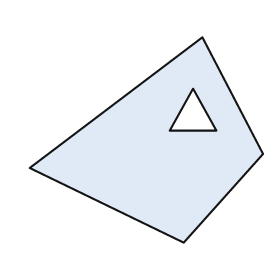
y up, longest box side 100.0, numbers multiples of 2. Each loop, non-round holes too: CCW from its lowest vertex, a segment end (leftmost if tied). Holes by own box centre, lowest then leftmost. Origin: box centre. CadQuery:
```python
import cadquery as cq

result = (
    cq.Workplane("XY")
    .moveTo(16.0, -44.0)
    .lineTo(50.0, -6.0)
    .lineTo(24.0, 44.0)
    .lineTo(-50.0, -12.0)
    .close()
    .moveTo(10.0, 4.0)
    .lineTo(30.0, 4.0)
    .lineTo(20.0, 22.0)
    .close()
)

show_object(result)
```